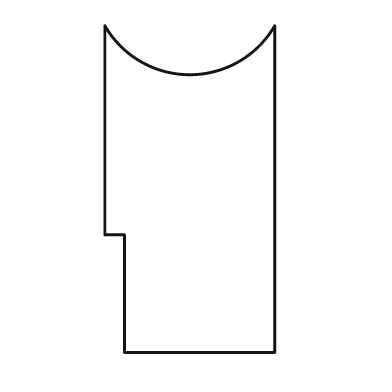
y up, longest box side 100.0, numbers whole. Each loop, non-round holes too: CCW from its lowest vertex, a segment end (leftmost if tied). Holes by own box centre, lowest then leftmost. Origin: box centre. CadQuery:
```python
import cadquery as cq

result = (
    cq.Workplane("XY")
    .moveTo(-20.0, -50.0)
    .lineTo(26.0, -50.0)
    .lineTo(26.0, 50.0)
    .threePointArc((0.0, 35.0), (-26.0, 50.0))
    .lineTo(-26.0, -14.0)
    .lineTo(-20.0, -14.0)
    .close()
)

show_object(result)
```